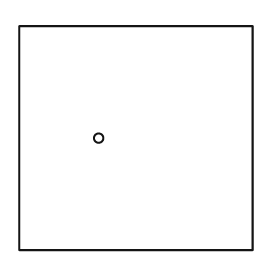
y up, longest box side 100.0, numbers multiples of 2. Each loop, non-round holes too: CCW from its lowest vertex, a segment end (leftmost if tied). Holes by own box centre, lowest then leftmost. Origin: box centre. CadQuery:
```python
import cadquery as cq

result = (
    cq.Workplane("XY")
    .moveTo(-50.0, -48.0)
    .lineTo(50.0, -48.0)
    .lineTo(50.0, 48.0)
    .lineTo(-50.0, 48.0)
    .close()
    .moveTo(-16.0, 0.0)
    .circle(2.0)
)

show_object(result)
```